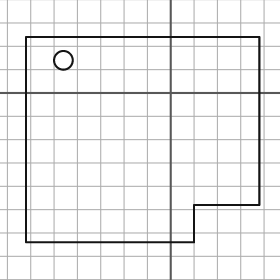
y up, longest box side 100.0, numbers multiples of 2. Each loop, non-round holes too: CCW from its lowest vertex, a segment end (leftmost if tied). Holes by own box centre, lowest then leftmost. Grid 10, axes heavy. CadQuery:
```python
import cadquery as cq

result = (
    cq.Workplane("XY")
    .moveTo(-62.0, -64.0)
    .lineTo(10.0, -64.0)
    .lineTo(10.0, -48.0)
    .lineTo(38.0, -48.0)
    .lineTo(38.0, 24.0)
    .lineTo(-62.0, 24.0)
    .close()
    .moveTo(-46.0, 14.0)
    .circle(4.0)
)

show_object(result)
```